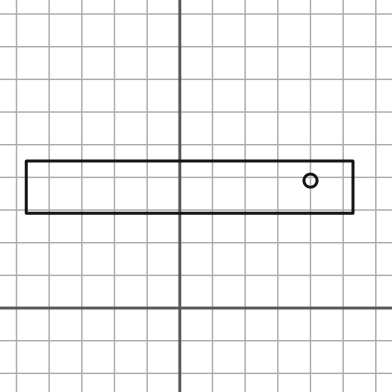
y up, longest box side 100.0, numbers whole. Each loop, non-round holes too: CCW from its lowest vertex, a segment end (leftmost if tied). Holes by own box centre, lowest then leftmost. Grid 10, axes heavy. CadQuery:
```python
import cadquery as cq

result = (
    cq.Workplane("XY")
    .moveTo(-47.0, 29.0)
    .lineTo(53.0, 29.0)
    .lineTo(53.0, 45.0)
    .lineTo(-47.0, 45.0)
    .close()
    .moveTo(40.0, 39.0)
    .circle(2.0)
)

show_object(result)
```